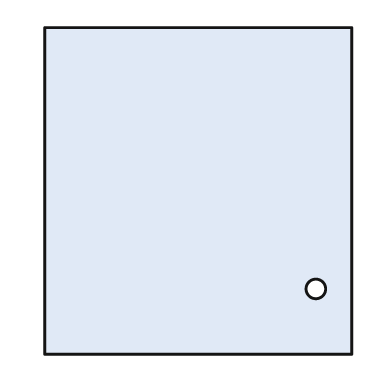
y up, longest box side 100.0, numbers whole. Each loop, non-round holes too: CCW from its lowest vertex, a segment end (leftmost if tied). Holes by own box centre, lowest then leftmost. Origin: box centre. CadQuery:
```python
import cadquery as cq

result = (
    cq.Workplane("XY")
    .moveTo(-47.0, -50.0)
    .lineTo(47.0, -50.0)
    .lineTo(47.0, 50.0)
    .lineTo(-47.0, 50.0)
    .close()
    .moveTo(36.0, -30.0)
    .circle(3.0)
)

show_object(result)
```